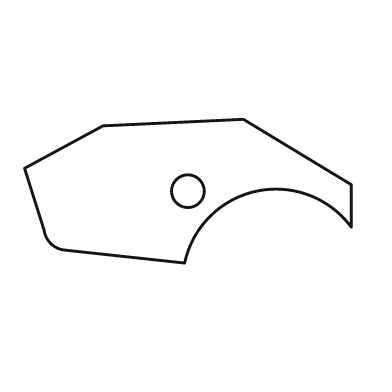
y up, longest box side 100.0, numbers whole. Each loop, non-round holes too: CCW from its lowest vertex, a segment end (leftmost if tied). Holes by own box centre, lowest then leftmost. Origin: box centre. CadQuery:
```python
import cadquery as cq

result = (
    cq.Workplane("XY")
    .moveTo(-1.0, -22.0)
    .threePointArc((21.0, 0.0), (50.0, -11.0))
    .lineTo(50.0, 2.0)
    .lineTo(17.0, 22.0)
    .lineTo(-26.0, 20.0)
    .lineTo(-50.0, 7.0)
    .lineTo(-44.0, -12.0)
    .threePointArc((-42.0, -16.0), (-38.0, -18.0))
    .close()
    .moveTo(0.0, 0.0)
    .circle(5.0)
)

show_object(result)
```